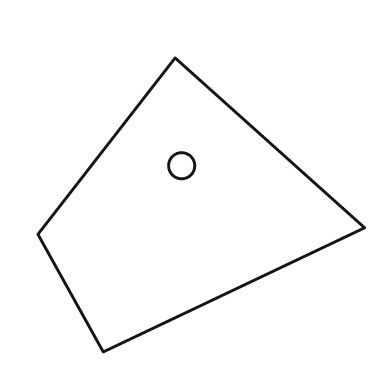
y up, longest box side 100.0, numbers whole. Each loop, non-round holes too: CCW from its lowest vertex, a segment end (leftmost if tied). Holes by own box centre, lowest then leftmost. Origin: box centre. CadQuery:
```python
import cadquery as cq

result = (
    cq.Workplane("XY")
    .moveTo(-30.0, -45.0)
    .lineTo(50.0, -7.0)
    .lineTo(-8.0, 45.0)
    .lineTo(-50.0, -9.0)
    .close()
    .moveTo(-6.0, 12.0)
    .circle(4.0)
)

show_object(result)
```